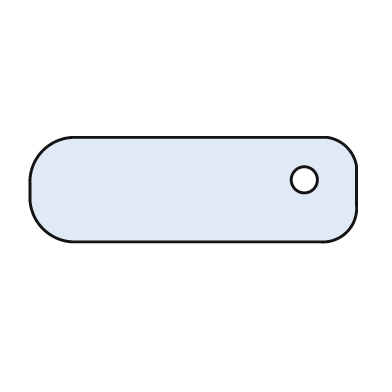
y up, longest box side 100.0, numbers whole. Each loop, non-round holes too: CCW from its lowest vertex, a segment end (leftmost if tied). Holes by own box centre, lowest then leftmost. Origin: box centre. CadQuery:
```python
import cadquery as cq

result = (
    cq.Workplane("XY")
    .moveTo(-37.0, -16.0)
    .lineTo(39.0, -16.0)
    .threePointArc((47.0, -13.0), (50.0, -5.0))
    .lineTo(50.0, 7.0)
    .threePointArc((47.0, 13.0), (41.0, 16.0))
    .lineTo(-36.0, 16.0)
    .threePointArc((-46.0, 12.0), (-50.0, 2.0))
    .lineTo(-50.0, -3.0)
    .threePointArc((-46.0, -12.0), (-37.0, -16.0))
    .close()
    .moveTo(34.0, 3.0)
    .circle(4.0)
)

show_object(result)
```